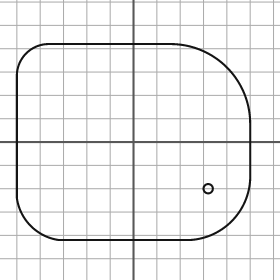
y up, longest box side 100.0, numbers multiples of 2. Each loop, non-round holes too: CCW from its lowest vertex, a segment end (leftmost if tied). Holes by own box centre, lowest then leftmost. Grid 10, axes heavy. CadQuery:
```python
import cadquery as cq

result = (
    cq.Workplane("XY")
    .moveTo(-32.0, -42.0)
    .lineTo(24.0, -42.0)
    .threePointArc((42.0, -34.0), (50.0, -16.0))
    .lineTo(50.0, 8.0)
    .threePointArc((40.0, 32.0), (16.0, 42.0))
    .lineTo(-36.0, 42.0)
    .threePointArc((-46.0, 38.0), (-50.0, 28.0))
    .lineTo(-50.0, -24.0)
    .threePointArc((-44.0, -36.0), (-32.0, -42.0))
    .close()
    .moveTo(32.0, -20.0)
    .circle(2.0)
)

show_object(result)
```